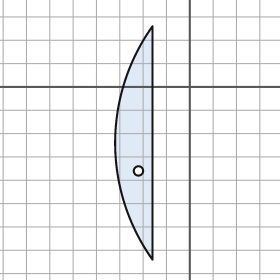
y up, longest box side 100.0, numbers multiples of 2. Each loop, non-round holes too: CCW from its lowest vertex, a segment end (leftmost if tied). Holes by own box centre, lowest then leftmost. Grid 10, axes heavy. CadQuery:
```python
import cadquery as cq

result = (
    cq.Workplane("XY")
    .moveTo(-16.0, -74.0)
    .lineTo(-16.0, 26.0)
    .threePointArc((-32.0, -24.0), (-16.0, -74.0))
    .close()
    .moveTo(-22.0, -36.0)
    .circle(2.0)
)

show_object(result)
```